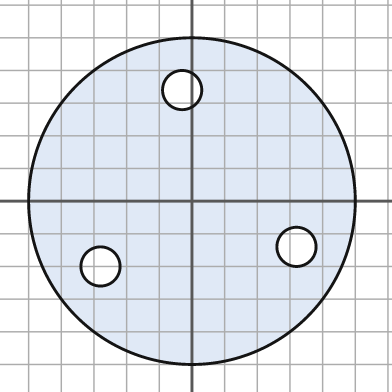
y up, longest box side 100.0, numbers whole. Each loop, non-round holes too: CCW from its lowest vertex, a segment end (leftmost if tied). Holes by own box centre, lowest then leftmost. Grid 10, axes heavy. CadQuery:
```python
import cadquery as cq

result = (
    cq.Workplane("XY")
    .moveTo(0.0, 0.0)
    .circle(50.0)
    .moveTo(-28.0, -20.0)
    .circle(6.0)
    .moveTo(32.0, -14.0)
    .circle(6.0)
    .moveTo(-3.0, 34.0)
    .circle(6.0)
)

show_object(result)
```